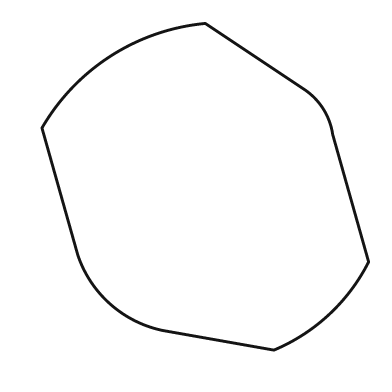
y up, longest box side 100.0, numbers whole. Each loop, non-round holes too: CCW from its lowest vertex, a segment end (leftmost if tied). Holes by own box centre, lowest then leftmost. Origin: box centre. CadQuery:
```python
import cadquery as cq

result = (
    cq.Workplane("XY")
    .moveTo(21.0, -50.0)
    .threePointArc((38.0, -39.0), (50.0, -23.0))
    .lineTo(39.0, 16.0)
    .threePointArc((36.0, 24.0), (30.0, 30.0))
    .lineTo(0.0, 50.0)
    .threePointArc((-29.0, 40.0), (-50.0, 18.0))
    .lineTo(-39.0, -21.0)
    .threePointArc((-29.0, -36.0), (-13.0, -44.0))
    .close()
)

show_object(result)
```